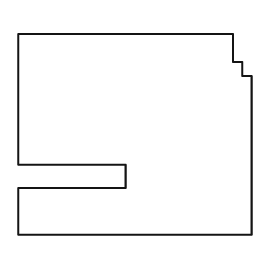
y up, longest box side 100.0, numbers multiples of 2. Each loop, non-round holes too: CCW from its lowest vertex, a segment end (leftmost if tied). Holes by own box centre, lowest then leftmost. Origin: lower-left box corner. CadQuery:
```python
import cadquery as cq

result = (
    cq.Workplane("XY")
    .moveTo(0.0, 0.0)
    .lineTo(100.0, 0.0)
    .lineTo(100.0, 68.0)
    .lineTo(96.0, 68.0)
    .lineTo(96.0, 74.0)
    .lineTo(92.0, 74.0)
    .lineTo(92.0, 86.0)
    .lineTo(0.0, 86.0)
    .lineTo(0.0, 30.0)
    .lineTo(46.0, 30.0)
    .lineTo(46.0, 20.0)
    .lineTo(0.0, 20.0)
    .close()
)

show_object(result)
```